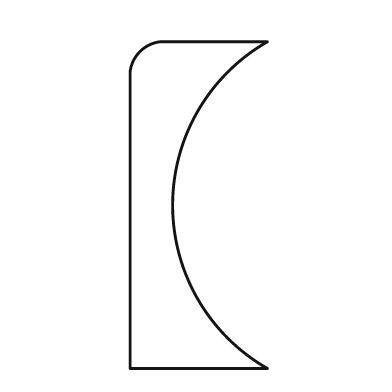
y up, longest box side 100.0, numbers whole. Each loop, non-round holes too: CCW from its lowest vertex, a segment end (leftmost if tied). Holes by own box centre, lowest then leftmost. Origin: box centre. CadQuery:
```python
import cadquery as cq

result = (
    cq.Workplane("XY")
    .moveTo(-21.0, -50.0)
    .lineTo(21.0, -50.0)
    .threePointArc((-8.0, 0.0), (21.0, 50.0))
    .lineTo(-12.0, 50.0)
    .threePointArc((-18.0, 47.0), (-21.0, 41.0))
    .close()
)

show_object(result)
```